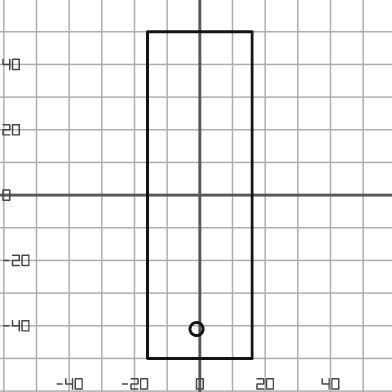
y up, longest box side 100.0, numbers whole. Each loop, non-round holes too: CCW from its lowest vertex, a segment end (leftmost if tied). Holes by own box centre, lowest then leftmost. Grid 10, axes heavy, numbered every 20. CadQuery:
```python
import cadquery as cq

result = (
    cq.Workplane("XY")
    .moveTo(-16.0, -50.0)
    .lineTo(16.0, -50.0)
    .lineTo(16.0, 50.0)
    .lineTo(-16.0, 50.0)
    .close()
    .moveTo(-1.0, -41.0)
    .circle(2.0)
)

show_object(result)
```